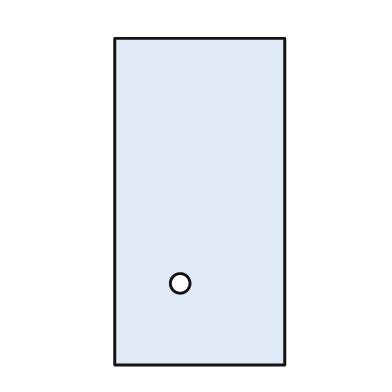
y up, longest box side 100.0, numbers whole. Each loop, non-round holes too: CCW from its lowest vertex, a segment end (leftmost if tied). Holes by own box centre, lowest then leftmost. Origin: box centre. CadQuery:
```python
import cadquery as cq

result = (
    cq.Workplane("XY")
    .moveTo(-26.0, -50.0)
    .lineTo(26.0, -50.0)
    .lineTo(26.0, 50.0)
    .lineTo(-26.0, 50.0)
    .close()
    .moveTo(-6.0, -25.0)
    .circle(3.0)
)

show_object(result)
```